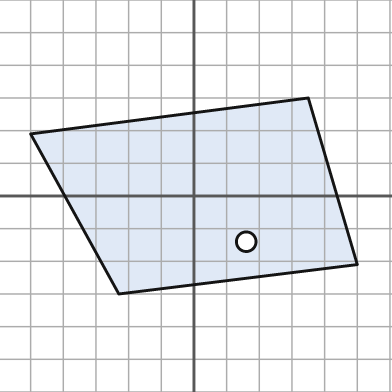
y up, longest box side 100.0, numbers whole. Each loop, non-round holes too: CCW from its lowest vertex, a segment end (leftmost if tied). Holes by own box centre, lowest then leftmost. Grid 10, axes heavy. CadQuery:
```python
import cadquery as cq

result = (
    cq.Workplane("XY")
    .moveTo(-23.0, -30.0)
    .lineTo(50.0, -21.0)
    .lineTo(35.0, 30.0)
    .lineTo(-50.0, 19.0)
    .close()
    .moveTo(16.0, -14.0)
    .circle(3.0)
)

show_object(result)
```